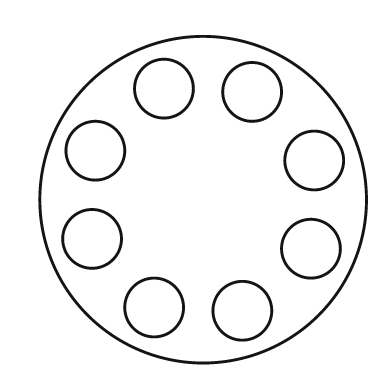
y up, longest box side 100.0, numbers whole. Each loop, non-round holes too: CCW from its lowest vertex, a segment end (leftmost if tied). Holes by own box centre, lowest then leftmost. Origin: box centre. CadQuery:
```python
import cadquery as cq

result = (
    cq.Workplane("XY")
    .moveTo(0.0, 0.0)
    .circle(50.0)
    .moveTo(12.0, -34.0)
    .circle(9.0)
    .moveTo(-15.0, -33.0)
    .circle(9.0)
    .moveTo(33.0, -15.0)
    .circle(9.0)
    .moveTo(-34.0, -12.0)
    .circle(9.0)
    .moveTo(34.0, 12.0)
    .circle(9.0)
    .moveTo(-33.0, 15.0)
    .circle(9.0)
    .moveTo(15.0, 33.0)
    .circle(9.0)
    .moveTo(-12.0, 34.0)
    .circle(9.0)
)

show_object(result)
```